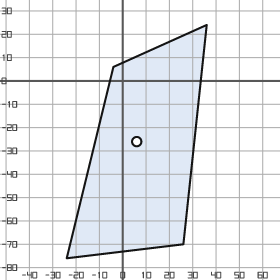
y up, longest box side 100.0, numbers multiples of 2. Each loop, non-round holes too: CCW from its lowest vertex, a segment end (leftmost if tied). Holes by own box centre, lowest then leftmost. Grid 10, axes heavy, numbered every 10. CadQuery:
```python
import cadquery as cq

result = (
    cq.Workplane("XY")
    .moveTo(-24.0, -76.0)
    .lineTo(26.0, -70.0)
    .lineTo(36.0, 24.0)
    .lineTo(-4.0, 6.0)
    .close()
    .moveTo(6.0, -26.0)
    .circle(2.0)
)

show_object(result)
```